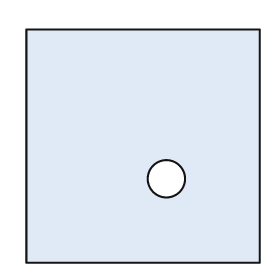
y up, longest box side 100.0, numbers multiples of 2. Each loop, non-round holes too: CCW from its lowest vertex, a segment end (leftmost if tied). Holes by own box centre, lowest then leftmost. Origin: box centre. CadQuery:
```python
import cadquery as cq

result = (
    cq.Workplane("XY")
    .moveTo(-50.0, -50.0)
    .lineTo(50.0, -50.0)
    .lineTo(50.0, 50.0)
    .lineTo(-50.0, 50.0)
    .close()
    .moveTo(10.0, -14.0)
    .circle(8.0)
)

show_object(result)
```